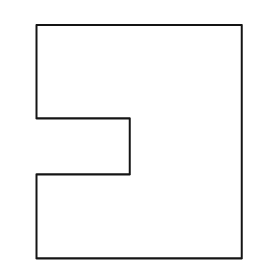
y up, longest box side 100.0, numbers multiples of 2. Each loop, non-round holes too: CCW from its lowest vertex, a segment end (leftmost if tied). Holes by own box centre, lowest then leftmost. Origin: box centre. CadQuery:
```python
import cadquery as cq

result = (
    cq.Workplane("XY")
    .moveTo(-44.0, -50.0)
    .lineTo(44.0, -50.0)
    .lineTo(44.0, 50.0)
    .lineTo(-44.0, 50.0)
    .lineTo(-44.0, 10.0)
    .lineTo(-4.0, 10.0)
    .lineTo(-4.0, -14.0)
    .lineTo(-44.0, -14.0)
    .close()
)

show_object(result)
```